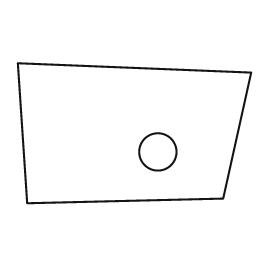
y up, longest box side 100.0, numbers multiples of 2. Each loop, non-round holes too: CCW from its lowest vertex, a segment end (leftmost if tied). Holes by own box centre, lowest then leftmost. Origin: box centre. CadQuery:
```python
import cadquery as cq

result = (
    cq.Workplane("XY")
    .moveTo(-46.0, -30.0)
    .lineTo(38.0, -28.0)
    .lineTo(50.0, 26.0)
    .lineTo(-50.0, 30.0)
    .close()
    .moveTo(10.0, -8.0)
    .circle(8.0)
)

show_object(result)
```